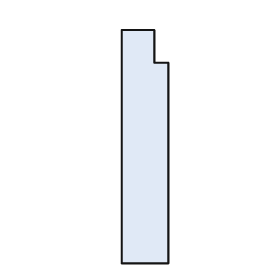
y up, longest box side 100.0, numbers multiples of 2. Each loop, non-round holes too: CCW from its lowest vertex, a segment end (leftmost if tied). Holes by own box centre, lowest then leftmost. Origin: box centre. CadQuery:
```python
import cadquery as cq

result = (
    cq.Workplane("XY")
    .moveTo(-10.0, -50.0)
    .lineTo(10.0, -50.0)
    .lineTo(10.0, 36.0)
    .lineTo(4.0, 36.0)
    .lineTo(4.0, 50.0)
    .lineTo(-10.0, 50.0)
    .close()
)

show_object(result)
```